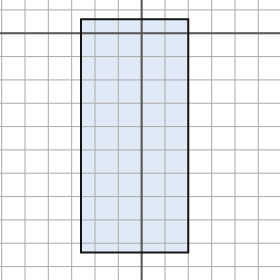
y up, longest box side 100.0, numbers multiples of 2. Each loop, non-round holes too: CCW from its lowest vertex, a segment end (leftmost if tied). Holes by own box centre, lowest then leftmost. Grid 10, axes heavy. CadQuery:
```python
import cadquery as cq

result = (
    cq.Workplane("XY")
    .moveTo(-26.0, -94.0)
    .lineTo(20.0, -94.0)
    .lineTo(20.0, 6.0)
    .lineTo(-26.0, 6.0)
    .close()
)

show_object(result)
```